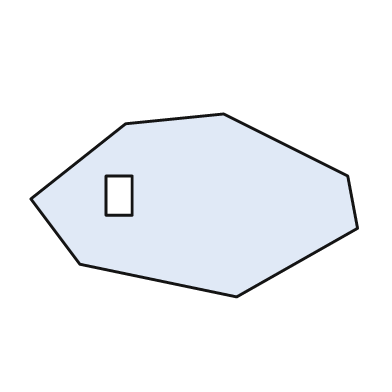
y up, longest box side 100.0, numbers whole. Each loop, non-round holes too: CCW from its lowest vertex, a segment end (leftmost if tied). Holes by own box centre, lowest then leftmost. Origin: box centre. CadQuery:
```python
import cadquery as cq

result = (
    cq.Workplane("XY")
    .moveTo(13.0, -28.0)
    .lineTo(50.0, -7.0)
    .lineTo(47.0, 9.0)
    .lineTo(9.0, 28.0)
    .lineTo(-21.0, 25.0)
    .lineTo(-50.0, 2.0)
    .lineTo(-35.0, -18.0)
    .close()
    .moveTo(-27.0, -3.0)
    .lineTo(-19.0, -3.0)
    .lineTo(-19.0, 9.0)
    .lineTo(-27.0, 9.0)
    .close()
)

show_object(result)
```